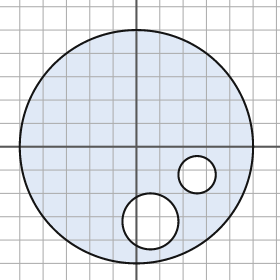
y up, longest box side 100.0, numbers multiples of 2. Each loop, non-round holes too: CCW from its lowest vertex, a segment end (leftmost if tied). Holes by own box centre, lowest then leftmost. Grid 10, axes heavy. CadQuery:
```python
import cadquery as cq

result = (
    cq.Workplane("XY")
    .moveTo(0.0, 0.0)
    .circle(50.0)
    .moveTo(6.0, -32.0)
    .circle(12.0)
    .moveTo(26.0, -12.0)
    .circle(8.0)
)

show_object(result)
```